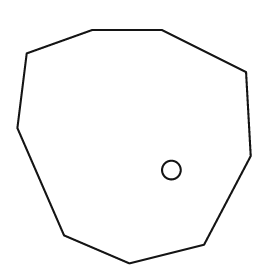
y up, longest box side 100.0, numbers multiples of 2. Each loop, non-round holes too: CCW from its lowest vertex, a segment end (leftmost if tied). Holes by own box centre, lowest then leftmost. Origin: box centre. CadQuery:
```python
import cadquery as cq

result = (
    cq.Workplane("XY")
    .moveTo(-2.0, -50.0)
    .lineTo(30.0, -42.0)
    .lineTo(50.0, -4.0)
    .lineTo(48.0, 32.0)
    .lineTo(12.0, 50.0)
    .lineTo(-18.0, 50.0)
    .lineTo(-46.0, 40.0)
    .lineTo(-50.0, 8.0)
    .lineTo(-30.0, -38.0)
    .close()
    .moveTo(16.0, -10.0)
    .circle(4.0)
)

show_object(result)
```